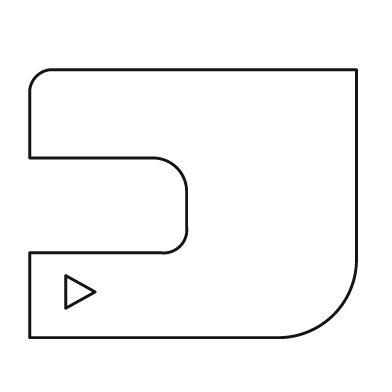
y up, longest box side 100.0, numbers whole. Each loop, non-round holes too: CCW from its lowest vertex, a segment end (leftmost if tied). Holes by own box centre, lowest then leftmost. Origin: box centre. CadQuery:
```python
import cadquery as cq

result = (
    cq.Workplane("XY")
    .moveTo(-50.0, -41.0)
    .lineTo(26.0, -41.0)
    .threePointArc((43.0, -34.0), (50.0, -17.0))
    .lineTo(50.0, 41.0)
    .lineTo(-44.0, 41.0)
    .threePointArc((-48.0, 39.0), (-50.0, 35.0))
    .lineTo(-50.0, 14.0)
    .lineTo(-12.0, 14.0)
    .threePointArc((-5.0, 11.0), (-2.0, 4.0))
    .lineTo(-2.0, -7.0)
    .threePointArc((-4.0, -13.0), (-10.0, -15.0))
    .lineTo(-50.0, -15.0)
    .close()
    .moveTo(-39.0, -32.0)
    .lineTo(-30.0, -27.0)
    .lineTo(-39.0, -22.0)
    .close()
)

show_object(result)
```